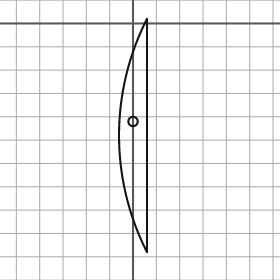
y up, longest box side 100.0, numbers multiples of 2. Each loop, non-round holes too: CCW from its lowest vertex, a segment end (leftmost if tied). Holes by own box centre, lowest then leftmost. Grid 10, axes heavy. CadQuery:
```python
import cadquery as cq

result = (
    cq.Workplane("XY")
    .moveTo(6.0, -98.0)
    .lineTo(6.0, 2.0)
    .threePointArc((-6.0, -48.0), (6.0, -98.0))
    .close()
    .moveTo(0.0, -42.0)
    .circle(2.0)
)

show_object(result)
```